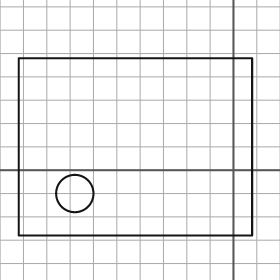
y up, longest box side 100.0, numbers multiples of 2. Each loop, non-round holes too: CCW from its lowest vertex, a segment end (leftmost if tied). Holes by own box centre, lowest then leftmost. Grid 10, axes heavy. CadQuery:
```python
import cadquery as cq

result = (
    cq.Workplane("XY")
    .moveTo(-92.0, -28.0)
    .lineTo(8.0, -28.0)
    .lineTo(8.0, 48.0)
    .lineTo(-92.0, 48.0)
    .close()
    .moveTo(-68.0, -10.0)
    .circle(8.0)
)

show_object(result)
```